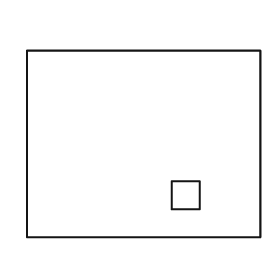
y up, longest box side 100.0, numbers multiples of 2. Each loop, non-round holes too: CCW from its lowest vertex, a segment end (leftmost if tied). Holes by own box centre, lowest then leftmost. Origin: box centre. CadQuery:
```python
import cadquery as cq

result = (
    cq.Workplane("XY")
    .moveTo(-50.0, -40.0)
    .lineTo(50.0, -40.0)
    .lineTo(50.0, 40.0)
    .lineTo(-50.0, 40.0)
    .close()
    .moveTo(12.0, -28.0)
    .lineTo(24.0, -28.0)
    .lineTo(24.0, -16.0)
    .lineTo(12.0, -16.0)
    .close()
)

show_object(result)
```